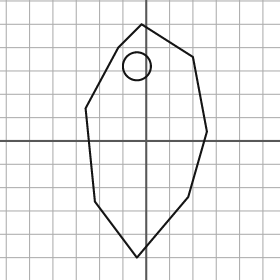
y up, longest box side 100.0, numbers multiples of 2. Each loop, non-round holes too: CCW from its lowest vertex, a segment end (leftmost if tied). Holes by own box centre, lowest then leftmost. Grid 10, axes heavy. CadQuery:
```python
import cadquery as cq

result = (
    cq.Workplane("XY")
    .moveTo(-4.0, -50.0)
    .lineTo(18.0, -24.0)
    .lineTo(26.0, 4.0)
    .lineTo(20.0, 36.0)
    .lineTo(-2.0, 50.0)
    .lineTo(-12.0, 40.0)
    .lineTo(-26.0, 14.0)
    .lineTo(-22.0, -26.0)
    .close()
    .moveTo(-4.0, 32.0)
    .circle(6.0)
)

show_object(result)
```